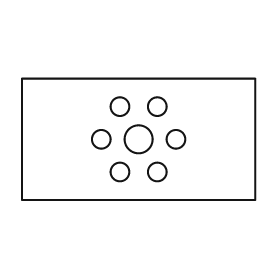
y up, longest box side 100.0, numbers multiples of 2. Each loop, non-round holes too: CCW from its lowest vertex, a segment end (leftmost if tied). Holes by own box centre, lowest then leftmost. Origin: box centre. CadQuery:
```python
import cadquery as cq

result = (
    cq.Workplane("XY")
    .moveTo(-50.0, -26.0)
    .lineTo(50.0, -26.0)
    .lineTo(50.0, 26.0)
    .lineTo(-50.0, 26.0)
    .close()
    .moveTo(-8.0, -14.0)
    .circle(4.0)
    .moveTo(8.0, -14.0)
    .circle(4.0)
    .moveTo(-16.0, 0.0)
    .circle(4.0)
    .moveTo(0.0, 0.0)
    .circle(6.0)
    .moveTo(16.0, 0.0)
    .circle(4.0)
    .moveTo(-8.0, 14.0)
    .circle(4.0)
    .moveTo(8.0, 14.0)
    .circle(4.0)
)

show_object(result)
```